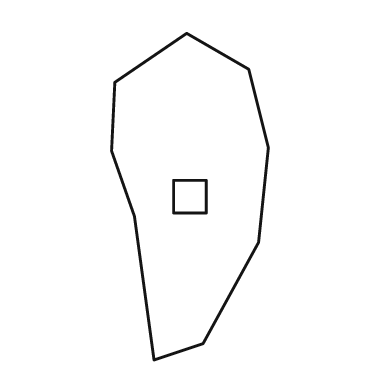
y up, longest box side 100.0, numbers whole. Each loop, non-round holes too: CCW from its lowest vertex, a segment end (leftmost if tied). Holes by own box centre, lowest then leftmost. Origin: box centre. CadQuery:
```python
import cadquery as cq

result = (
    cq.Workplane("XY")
    .moveTo(-11.0, -50.0)
    .lineTo(4.0, -45.0)
    .lineTo(21.0, -14.0)
    .lineTo(24.0, 15.0)
    .lineTo(18.0, 39.0)
    .lineTo(-1.0, 50.0)
    .lineTo(-23.0, 35.0)
    .lineTo(-24.0, 14.0)
    .lineTo(-17.0, -6.0)
    .close()
    .moveTo(-5.0, -5.0)
    .lineTo(5.0, -5.0)
    .lineTo(5.0, 5.0)
    .lineTo(-5.0, 5.0)
    .close()
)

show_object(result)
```